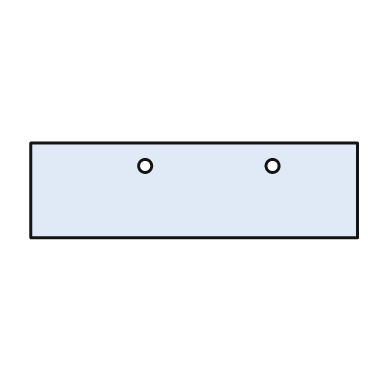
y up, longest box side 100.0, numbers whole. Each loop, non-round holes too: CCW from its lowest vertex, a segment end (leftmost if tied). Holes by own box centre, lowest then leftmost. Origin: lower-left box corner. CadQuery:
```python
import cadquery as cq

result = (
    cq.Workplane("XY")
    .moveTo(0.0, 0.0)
    .lineTo(100.0, 0.0)
    .lineTo(100.0, 29.0)
    .lineTo(0.0, 29.0)
    .close()
    .moveTo(35.0, 22.0)
    .circle(2.0)
    .moveTo(74.0, 22.0)
    .circle(2.0)
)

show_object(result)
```